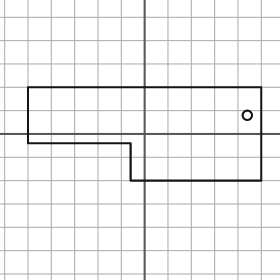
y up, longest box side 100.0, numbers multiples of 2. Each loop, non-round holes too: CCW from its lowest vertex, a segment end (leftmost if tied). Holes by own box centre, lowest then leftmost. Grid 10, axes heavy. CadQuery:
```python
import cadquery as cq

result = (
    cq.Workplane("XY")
    .moveTo(-6.0, -20.0)
    .lineTo(50.0, -20.0)
    .lineTo(50.0, 20.0)
    .lineTo(-50.0, 20.0)
    .lineTo(-50.0, -4.0)
    .lineTo(-6.0, -4.0)
    .close()
    .moveTo(44.0, 8.0)
    .circle(2.0)
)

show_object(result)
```